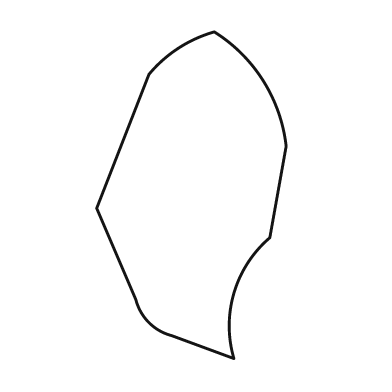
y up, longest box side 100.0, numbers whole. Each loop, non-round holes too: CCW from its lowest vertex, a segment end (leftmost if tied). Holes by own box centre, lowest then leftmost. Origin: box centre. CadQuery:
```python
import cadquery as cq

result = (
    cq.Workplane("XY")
    .moveTo(13.0, -50.0)
    .threePointArc((13.0, -30.0), (24.0, -13.0))
    .lineTo(29.0, 15.0)
    .threePointArc((22.0, 35.0), (7.0, 50.0))
    .threePointArc((-4.0, 45.0), (-13.0, 37.0))
    .lineTo(-29.0, -4.0)
    .lineTo(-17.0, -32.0)
    .threePointArc((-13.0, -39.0), (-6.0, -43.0))
    .close()
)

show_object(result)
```